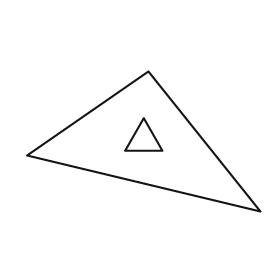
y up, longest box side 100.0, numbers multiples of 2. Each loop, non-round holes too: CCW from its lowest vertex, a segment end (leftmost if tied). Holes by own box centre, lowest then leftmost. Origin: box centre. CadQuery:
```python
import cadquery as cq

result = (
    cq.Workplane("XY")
    .moveTo(50.0, -30.0)
    .lineTo(2.0, 30.0)
    .lineTo(-50.0, -6.0)
    .close()
    .moveTo(-8.0, -4.0)
    .lineTo(8.0, -4.0)
    .lineTo(0.0, 10.0)
    .close()
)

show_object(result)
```